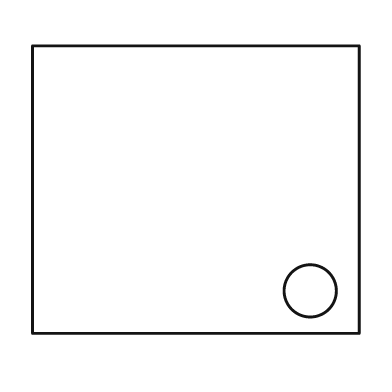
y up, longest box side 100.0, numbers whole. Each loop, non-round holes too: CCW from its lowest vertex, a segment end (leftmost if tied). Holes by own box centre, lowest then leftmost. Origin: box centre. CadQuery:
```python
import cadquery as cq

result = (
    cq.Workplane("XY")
    .moveTo(-50.0, -44.0)
    .lineTo(50.0, -44.0)
    .lineTo(50.0, 44.0)
    .lineTo(-50.0, 44.0)
    .close()
    .moveTo(35.0, -31.0)
    .circle(8.0)
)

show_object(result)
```